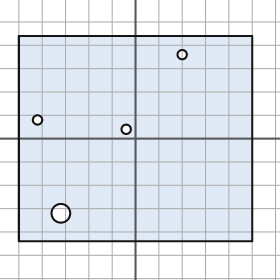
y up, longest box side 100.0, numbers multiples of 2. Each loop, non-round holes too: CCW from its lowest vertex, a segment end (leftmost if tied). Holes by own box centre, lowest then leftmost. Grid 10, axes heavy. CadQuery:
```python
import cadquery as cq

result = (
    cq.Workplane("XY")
    .moveTo(-50.0, -44.0)
    .lineTo(50.0, -44.0)
    .lineTo(50.0, 44.0)
    .lineTo(-50.0, 44.0)
    .close()
    .moveTo(-32.0, -32.0)
    .circle(4.0)
    .moveTo(-4.0, 4.0)
    .circle(2.0)
    .moveTo(-42.0, 8.0)
    .circle(2.0)
    .moveTo(20.0, 36.0)
    .circle(2.0)
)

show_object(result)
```